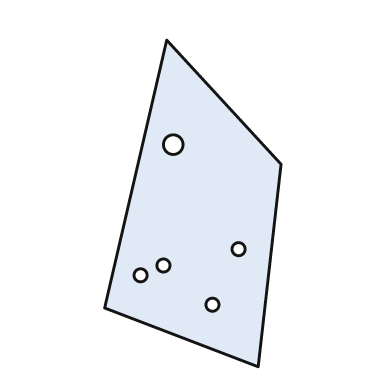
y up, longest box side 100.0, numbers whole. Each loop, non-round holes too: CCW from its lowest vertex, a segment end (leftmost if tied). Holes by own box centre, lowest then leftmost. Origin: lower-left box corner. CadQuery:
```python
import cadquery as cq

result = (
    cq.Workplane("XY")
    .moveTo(47.0, 0.0)
    .lineTo(54.0, 62.0)
    .lineTo(19.0, 100.0)
    .lineTo(0.0, 18.0)
    .close()
    .moveTo(33.0, 19.0)
    .circle(2.0)
    .moveTo(11.0, 28.0)
    .circle(2.0)
    .moveTo(18.0, 31.0)
    .circle(2.0)
    .moveTo(41.0, 36.0)
    .circle(2.0)
    .moveTo(21.0, 68.0)
    .circle(3.0)
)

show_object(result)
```